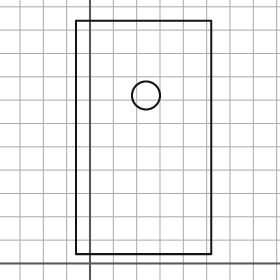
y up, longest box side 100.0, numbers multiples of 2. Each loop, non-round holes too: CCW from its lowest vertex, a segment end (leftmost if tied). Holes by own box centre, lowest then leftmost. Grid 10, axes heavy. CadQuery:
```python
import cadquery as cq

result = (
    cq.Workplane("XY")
    .moveTo(-6.0, 4.0)
    .lineTo(52.0, 4.0)
    .lineTo(52.0, 104.0)
    .lineTo(-6.0, 104.0)
    .close()
    .moveTo(24.0, 72.0)
    .circle(6.0)
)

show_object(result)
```